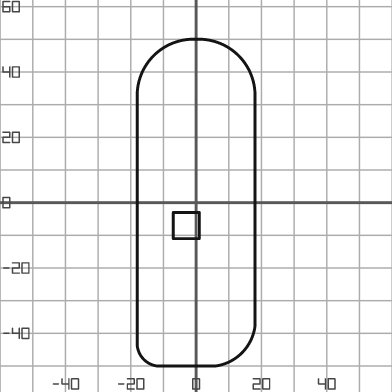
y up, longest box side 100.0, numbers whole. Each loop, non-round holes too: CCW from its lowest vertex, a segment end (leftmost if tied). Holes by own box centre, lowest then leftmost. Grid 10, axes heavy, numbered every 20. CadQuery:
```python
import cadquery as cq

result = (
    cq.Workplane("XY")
    .moveTo(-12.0, -50.0)
    .lineTo(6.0, -50.0)
    .threePointArc((14.0, -46.0), (18.0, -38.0))
    .lineTo(18.0, 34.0)
    .threePointArc((13.0, 45.0), (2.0, 50.0))
    .lineTo(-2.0, 50.0)
    .threePointArc((-13.0, 45.0), (-18.0, 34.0))
    .lineTo(-18.0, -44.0)
    .threePointArc((-16.0, -48.0), (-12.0, -50.0))
    .close()
    .moveTo(-7.0, -11.0)
    .lineTo(1.0, -11.0)
    .lineTo(1.0, -3.0)
    .lineTo(-7.0, -3.0)
    .close()
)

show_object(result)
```